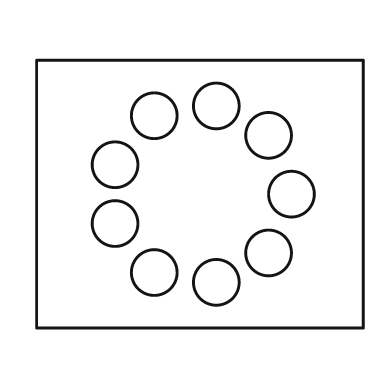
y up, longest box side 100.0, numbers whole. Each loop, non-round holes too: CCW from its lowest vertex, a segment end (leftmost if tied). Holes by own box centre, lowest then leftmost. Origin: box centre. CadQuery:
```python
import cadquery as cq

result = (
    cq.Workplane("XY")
    .moveTo(-50.0, -41.0)
    .lineTo(50.0, -41.0)
    .lineTo(50.0, 41.0)
    .lineTo(-50.0, 41.0)
    .close()
    .moveTo(5.0, -27.0)
    .circle(7.0)
    .moveTo(-14.0, -24.0)
    .circle(7.0)
    .moveTo(21.0, -18.0)
    .circle(7.0)
    .moveTo(-26.0, -9.0)
    .circle(7.0)
    .moveTo(28.0, 0.0)
    .circle(7.0)
    .moveTo(-26.0, 9.0)
    .circle(7.0)
    .moveTo(21.0, 18.0)
    .circle(7.0)
    .moveTo(-14.0, 24.0)
    .circle(7.0)
    .moveTo(5.0, 27.0)
    .circle(7.0)
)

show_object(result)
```